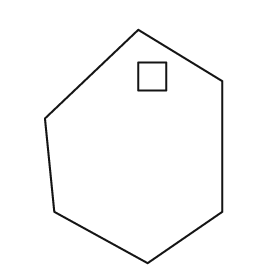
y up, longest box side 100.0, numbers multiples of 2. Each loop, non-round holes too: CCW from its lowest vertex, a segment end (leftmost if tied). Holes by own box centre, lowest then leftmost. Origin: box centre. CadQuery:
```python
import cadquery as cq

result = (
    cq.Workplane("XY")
    .moveTo(6.0, -50.0)
    .lineTo(38.0, -28.0)
    .lineTo(38.0, 28.0)
    .lineTo(2.0, 50.0)
    .lineTo(-38.0, 12.0)
    .lineTo(-34.0, -28.0)
    .close()
    .moveTo(2.0, 24.0)
    .lineTo(14.0, 24.0)
    .lineTo(14.0, 36.0)
    .lineTo(2.0, 36.0)
    .close()
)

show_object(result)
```